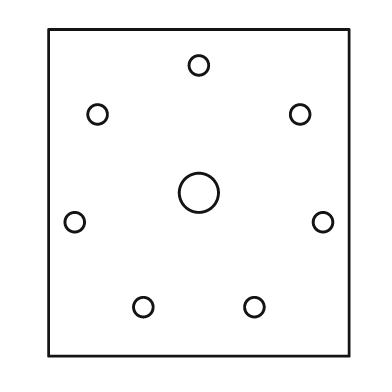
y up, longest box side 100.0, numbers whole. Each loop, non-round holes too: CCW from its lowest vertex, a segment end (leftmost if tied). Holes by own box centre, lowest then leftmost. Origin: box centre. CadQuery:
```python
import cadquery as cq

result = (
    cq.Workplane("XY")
    .moveTo(-46.0, -50.0)
    .lineTo(46.0, -50.0)
    .lineTo(46.0, 50.0)
    .lineTo(-46.0, 50.0)
    .close()
    .moveTo(-17.0, -35.0)
    .circle(3.0)
    .moveTo(17.0, -35.0)
    .circle(3.0)
    .moveTo(-38.0, -9.0)
    .circle(3.0)
    .moveTo(38.0, -9.0)
    .circle(3.0)
    .moveTo(0.0, 0.0)
    .circle(6.0)
    .moveTo(-31.0, 24.0)
    .circle(3.0)
    .moveTo(31.0, 24.0)
    .circle(3.0)
    .moveTo(0.0, 39.0)
    .circle(3.0)
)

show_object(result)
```